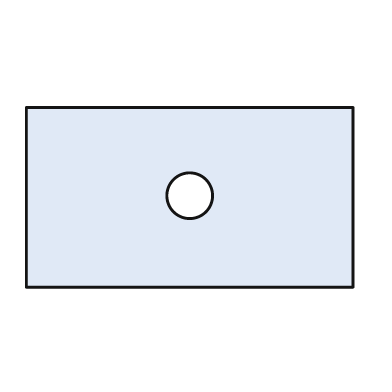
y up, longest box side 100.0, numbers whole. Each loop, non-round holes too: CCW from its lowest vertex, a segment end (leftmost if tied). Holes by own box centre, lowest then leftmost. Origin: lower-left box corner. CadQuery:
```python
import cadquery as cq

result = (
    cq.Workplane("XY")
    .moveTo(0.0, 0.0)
    .lineTo(100.0, 0.0)
    .lineTo(100.0, 55.0)
    .lineTo(0.0, 55.0)
    .close()
    .moveTo(50.0, 28.0)
    .circle(7.0)
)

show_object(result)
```